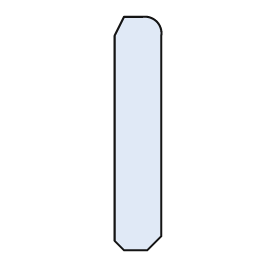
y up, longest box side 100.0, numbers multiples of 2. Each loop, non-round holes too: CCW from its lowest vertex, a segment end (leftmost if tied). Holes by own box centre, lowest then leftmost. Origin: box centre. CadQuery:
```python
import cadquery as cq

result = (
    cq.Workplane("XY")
    .moveTo(-6.0, -50.0)
    .lineTo(4.0, -50.0)
    .lineTo(10.0, -44.0)
    .lineTo(10.0, 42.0)
    .threePointArc((8.0, 48.0), (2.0, 50.0))
    .lineTo(-6.0, 50.0)
    .lineTo(-10.0, 42.0)
    .lineTo(-10.0, -46.0)
    .close()
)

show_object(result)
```